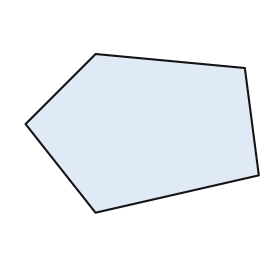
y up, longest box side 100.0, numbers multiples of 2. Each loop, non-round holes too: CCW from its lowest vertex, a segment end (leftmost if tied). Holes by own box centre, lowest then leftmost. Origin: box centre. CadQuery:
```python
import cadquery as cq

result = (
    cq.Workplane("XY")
    .moveTo(-20.0, -34.0)
    .lineTo(50.0, -18.0)
    .lineTo(44.0, 28.0)
    .lineTo(-20.0, 34.0)
    .lineTo(-50.0, 4.0)
    .close()
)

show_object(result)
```